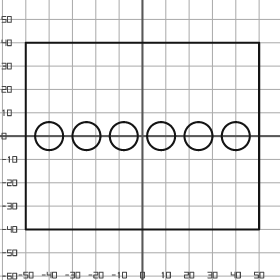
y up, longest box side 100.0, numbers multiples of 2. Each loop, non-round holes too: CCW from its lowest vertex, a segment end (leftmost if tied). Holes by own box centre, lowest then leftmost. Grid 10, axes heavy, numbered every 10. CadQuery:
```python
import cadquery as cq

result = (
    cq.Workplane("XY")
    .moveTo(-50.0, -40.0)
    .lineTo(50.0, -40.0)
    .lineTo(50.0, 40.0)
    .lineTo(-50.0, 40.0)
    .close()
    .moveTo(-40.0, 0.0)
    .circle(6.0)
    .moveTo(-24.0, 0.0)
    .circle(6.0)
    .moveTo(-8.0, 0.0)
    .circle(6.0)
    .moveTo(8.0, 0.0)
    .circle(6.0)
    .moveTo(24.0, 0.0)
    .circle(6.0)
    .moveTo(40.0, 0.0)
    .circle(6.0)
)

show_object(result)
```